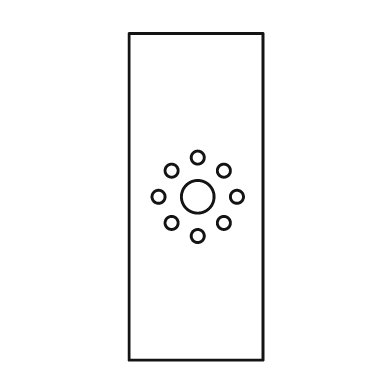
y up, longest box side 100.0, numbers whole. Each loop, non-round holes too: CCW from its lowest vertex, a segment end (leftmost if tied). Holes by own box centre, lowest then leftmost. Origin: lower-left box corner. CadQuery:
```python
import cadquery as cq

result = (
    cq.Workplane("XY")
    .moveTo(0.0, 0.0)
    .lineTo(41.0, 0.0)
    .lineTo(41.0, 100.0)
    .lineTo(0.0, 100.0)
    .close()
    .moveTo(21.0, 38.0)
    .circle(2.0)
    .moveTo(13.0, 42.0)
    .circle(2.0)
    .moveTo(29.0, 42.0)
    .circle(2.0)
    .moveTo(9.0, 50.0)
    .circle(2.0)
    .moveTo(21.0, 50.0)
    .circle(5.0)
    .moveTo(33.0, 50.0)
    .circle(2.0)
    .moveTo(13.0, 58.0)
    .circle(2.0)
    .moveTo(29.0, 58.0)
    .circle(2.0)
    .moveTo(21.0, 62.0)
    .circle(2.0)
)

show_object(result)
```